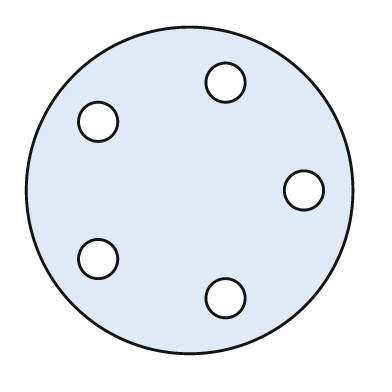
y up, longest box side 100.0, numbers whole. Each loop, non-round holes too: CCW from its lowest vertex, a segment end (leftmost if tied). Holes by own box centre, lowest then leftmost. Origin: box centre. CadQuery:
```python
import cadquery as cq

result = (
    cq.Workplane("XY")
    .moveTo(0.0, 0.0)
    .circle(50.0)
    .moveTo(11.0, -33.0)
    .circle(6.0)
    .moveTo(-28.0, -21.0)
    .circle(6.0)
    .moveTo(35.0, 0.0)
    .circle(6.0)
    .moveTo(-28.0, 21.0)
    .circle(6.0)
    .moveTo(11.0, 33.0)
    .circle(6.0)
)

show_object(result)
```